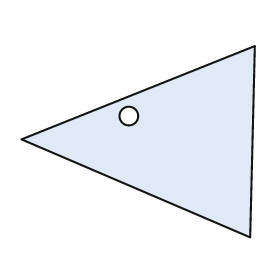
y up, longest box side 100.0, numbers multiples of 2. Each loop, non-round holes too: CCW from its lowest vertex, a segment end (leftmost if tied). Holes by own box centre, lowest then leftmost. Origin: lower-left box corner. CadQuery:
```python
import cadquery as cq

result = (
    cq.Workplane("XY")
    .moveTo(98.0, 0.0)
    .lineTo(100.0, 82.0)
    .lineTo(0.0, 42.0)
    .close()
    .moveTo(46.0, 52.0)
    .circle(4.0)
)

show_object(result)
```